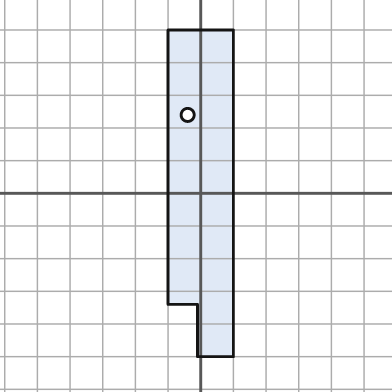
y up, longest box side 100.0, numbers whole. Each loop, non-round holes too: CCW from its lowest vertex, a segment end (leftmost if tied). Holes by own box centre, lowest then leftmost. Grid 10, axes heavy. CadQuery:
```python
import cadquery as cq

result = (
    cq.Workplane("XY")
    .moveTo(-1.0, -50.0)
    .lineTo(10.0, -50.0)
    .lineTo(10.0, 50.0)
    .lineTo(-10.0, 50.0)
    .lineTo(-10.0, -34.0)
    .lineTo(-1.0, -34.0)
    .close()
    .moveTo(-4.0, 24.0)
    .circle(2.0)
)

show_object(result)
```